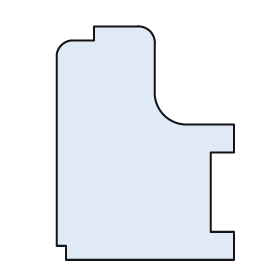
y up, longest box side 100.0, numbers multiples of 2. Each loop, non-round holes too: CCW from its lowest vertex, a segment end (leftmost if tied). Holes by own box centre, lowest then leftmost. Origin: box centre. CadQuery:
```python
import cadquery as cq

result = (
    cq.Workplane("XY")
    .moveTo(-34.0, -50.0)
    .lineTo(38.0, -50.0)
    .lineTo(38.0, -38.0)
    .lineTo(28.0, -38.0)
    .lineTo(28.0, -4.0)
    .lineTo(38.0, -4.0)
    .lineTo(38.0, 8.0)
    .lineTo(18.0, 8.0)
    .threePointArc((8.0, 12.0), (4.0, 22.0))
    .lineTo(4.0, 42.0)
    .threePointArc((2.0, 48.0), (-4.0, 50.0))
    .lineTo(-22.0, 50.0)
    .lineTo(-22.0, 44.0)
    .lineTo(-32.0, 44.0)
    .threePointArc((-36.0, 42.0), (-38.0, 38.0))
    .lineTo(-38.0, -44.0)
    .lineTo(-34.0, -44.0)
    .close()
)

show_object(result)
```